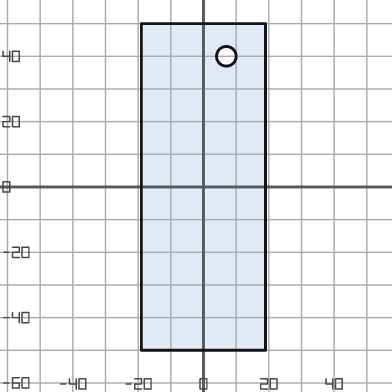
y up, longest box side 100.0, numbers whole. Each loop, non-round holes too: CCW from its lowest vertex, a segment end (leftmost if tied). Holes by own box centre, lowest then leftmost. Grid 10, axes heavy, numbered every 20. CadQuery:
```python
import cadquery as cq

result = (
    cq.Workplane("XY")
    .moveTo(-19.0, -50.0)
    .lineTo(19.0, -50.0)
    .lineTo(19.0, 50.0)
    .lineTo(-19.0, 50.0)
    .close()
    .moveTo(7.0, 40.0)
    .circle(3.0)
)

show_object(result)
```